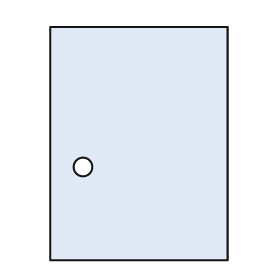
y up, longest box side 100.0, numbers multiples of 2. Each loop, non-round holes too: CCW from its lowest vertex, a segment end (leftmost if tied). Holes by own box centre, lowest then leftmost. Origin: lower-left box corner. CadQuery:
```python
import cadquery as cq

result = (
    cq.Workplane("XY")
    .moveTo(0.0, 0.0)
    .lineTo(76.0, 0.0)
    .lineTo(76.0, 100.0)
    .lineTo(0.0, 100.0)
    .close()
    .moveTo(14.0, 40.0)
    .circle(4.0)
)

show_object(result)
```